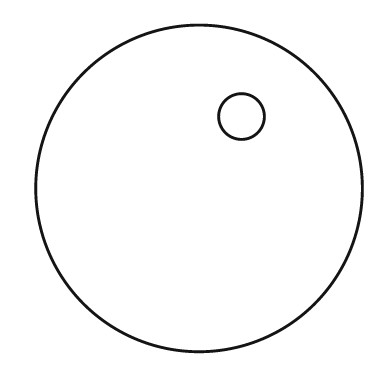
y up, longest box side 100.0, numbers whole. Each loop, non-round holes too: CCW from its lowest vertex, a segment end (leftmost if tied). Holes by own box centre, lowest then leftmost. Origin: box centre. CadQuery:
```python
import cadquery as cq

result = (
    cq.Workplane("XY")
    .moveTo(0.0, 0.0)
    .circle(50.0)
    .moveTo(13.0, 22.0)
    .circle(7.0)
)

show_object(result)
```